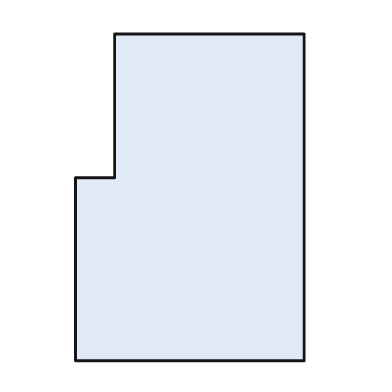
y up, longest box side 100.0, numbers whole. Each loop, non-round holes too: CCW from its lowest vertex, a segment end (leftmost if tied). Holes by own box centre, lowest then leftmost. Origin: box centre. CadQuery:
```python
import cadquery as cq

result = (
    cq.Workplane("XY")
    .moveTo(-35.0, -50.0)
    .lineTo(35.0, -50.0)
    .lineTo(35.0, 50.0)
    .lineTo(-23.0, 50.0)
    .lineTo(-23.0, 6.0)
    .lineTo(-35.0, 6.0)
    .close()
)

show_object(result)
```